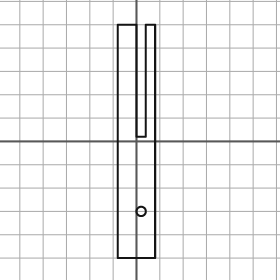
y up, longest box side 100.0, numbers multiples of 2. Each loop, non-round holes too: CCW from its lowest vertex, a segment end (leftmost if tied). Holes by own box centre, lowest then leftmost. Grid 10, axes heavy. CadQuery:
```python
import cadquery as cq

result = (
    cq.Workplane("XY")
    .moveTo(-8.0, -50.0)
    .lineTo(8.0, -50.0)
    .lineTo(8.0, 50.0)
    .lineTo(4.0, 50.0)
    .lineTo(4.0, 2.0)
    .lineTo(0.0, 2.0)
    .lineTo(0.0, 50.0)
    .lineTo(-8.0, 50.0)
    .close()
    .moveTo(2.0, -30.0)
    .circle(2.0)
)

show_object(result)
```